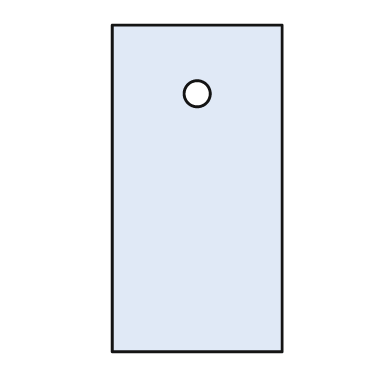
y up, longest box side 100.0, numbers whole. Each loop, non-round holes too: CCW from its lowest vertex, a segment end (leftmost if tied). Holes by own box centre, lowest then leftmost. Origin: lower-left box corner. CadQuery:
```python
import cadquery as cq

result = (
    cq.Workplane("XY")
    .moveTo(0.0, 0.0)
    .lineTo(52.0, 0.0)
    .lineTo(52.0, 100.0)
    .lineTo(0.0, 100.0)
    .close()
    .moveTo(26.0, 79.0)
    .circle(4.0)
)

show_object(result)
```